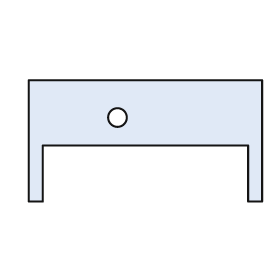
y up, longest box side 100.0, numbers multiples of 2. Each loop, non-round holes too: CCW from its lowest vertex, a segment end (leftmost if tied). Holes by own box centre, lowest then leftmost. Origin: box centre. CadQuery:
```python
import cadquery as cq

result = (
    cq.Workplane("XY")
    .moveTo(-50.0, -26.0)
    .lineTo(-44.0, -26.0)
    .lineTo(-44.0, -2.0)
    .lineTo(44.0, -2.0)
    .lineTo(44.0, -26.0)
    .lineTo(50.0, -26.0)
    .lineTo(50.0, 26.0)
    .lineTo(-50.0, 26.0)
    .close()
    .moveTo(-12.0, 10.0)
    .circle(4.0)
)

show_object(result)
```